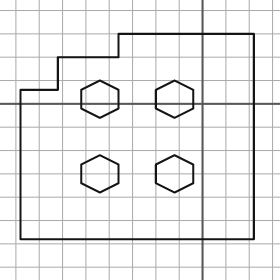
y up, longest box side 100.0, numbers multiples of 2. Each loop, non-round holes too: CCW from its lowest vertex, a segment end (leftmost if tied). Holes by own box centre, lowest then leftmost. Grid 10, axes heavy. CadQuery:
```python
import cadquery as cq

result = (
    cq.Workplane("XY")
    .moveTo(-78.0, -58.0)
    .lineTo(22.0, -58.0)
    .lineTo(22.0, 30.0)
    .lineTo(-36.0, 30.0)
    .lineTo(-36.0, 20.0)
    .lineTo(-62.0, 20.0)
    .lineTo(-62.0, 6.0)
    .lineTo(-78.0, 6.0)
    .close()
    .moveTo(-44.0, -38.0)
    .lineTo(-36.0, -34.0)
    .lineTo(-36.0, -26.0)
    .lineTo(-44.0, -22.0)
    .lineTo(-52.0, -26.0)
    .lineTo(-52.0, -34.0)
    .close()
    .moveTo(-12.0, -38.0)
    .lineTo(-4.0, -34.0)
    .lineTo(-4.0, -26.0)
    .lineTo(-12.0, -22.0)
    .lineTo(-20.0, -26.0)
    .lineTo(-20.0, -34.0)
    .close()
    .moveTo(-44.0, -6.0)
    .lineTo(-36.0, -2.0)
    .lineTo(-36.0, 6.0)
    .lineTo(-44.0, 10.0)
    .lineTo(-52.0, 6.0)
    .lineTo(-52.0, -2.0)
    .close()
    .moveTo(-12.0, -6.0)
    .lineTo(-4.0, -2.0)
    .lineTo(-4.0, 6.0)
    .lineTo(-12.0, 10.0)
    .lineTo(-20.0, 6.0)
    .lineTo(-20.0, -2.0)
    .close()
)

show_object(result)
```